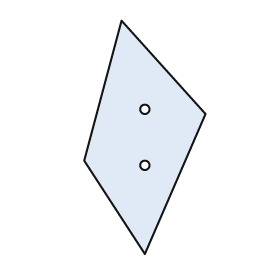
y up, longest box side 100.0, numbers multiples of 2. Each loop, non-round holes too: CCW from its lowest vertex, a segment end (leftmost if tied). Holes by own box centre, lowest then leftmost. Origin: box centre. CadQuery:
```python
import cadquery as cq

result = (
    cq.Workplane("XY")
    .moveTo(0.0, -50.0)
    .lineTo(26.0, 10.0)
    .lineTo(-10.0, 50.0)
    .lineTo(-26.0, -10.0)
    .close()
    .moveTo(0.0, -12.0)
    .circle(2.0)
    .moveTo(0.0, 12.0)
    .circle(2.0)
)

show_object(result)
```